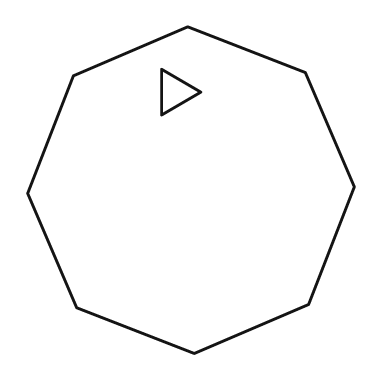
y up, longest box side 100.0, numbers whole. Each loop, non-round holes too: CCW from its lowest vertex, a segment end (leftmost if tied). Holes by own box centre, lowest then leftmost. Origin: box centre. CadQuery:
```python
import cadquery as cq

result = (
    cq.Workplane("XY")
    .moveTo(1.0, -50.0)
    .lineTo(36.0, -35.0)
    .lineTo(50.0, 1.0)
    .lineTo(35.0, 36.0)
    .lineTo(-1.0, 50.0)
    .lineTo(-36.0, 35.0)
    .lineTo(-50.0, -1.0)
    .lineTo(-35.0, -36.0)
    .close()
    .moveTo(-9.0, 23.0)
    .lineTo(3.0, 30.0)
    .lineTo(-9.0, 37.0)
    .close()
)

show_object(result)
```